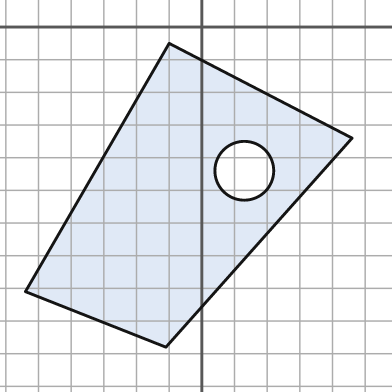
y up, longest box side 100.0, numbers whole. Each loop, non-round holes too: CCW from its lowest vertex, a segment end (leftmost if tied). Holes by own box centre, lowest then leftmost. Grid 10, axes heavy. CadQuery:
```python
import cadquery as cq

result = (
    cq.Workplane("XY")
    .moveTo(-11.0, -98.0)
    .lineTo(46.0, -34.0)
    .lineTo(-10.0, -5.0)
    .lineTo(-54.0, -81.0)
    .close()
    .moveTo(13.0, -44.0)
    .circle(9.0)
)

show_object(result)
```